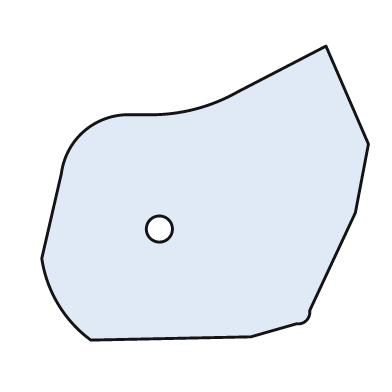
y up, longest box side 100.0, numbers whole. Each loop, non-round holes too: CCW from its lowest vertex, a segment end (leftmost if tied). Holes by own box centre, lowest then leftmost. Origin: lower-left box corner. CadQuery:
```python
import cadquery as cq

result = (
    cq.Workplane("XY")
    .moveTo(15.0, 0.0)
    .lineTo(64.0, 1.0)
    .lineTo(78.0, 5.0)
    .threePointArc((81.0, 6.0), (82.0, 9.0))
    .lineTo(96.0, 39.0)
    .lineTo(100.0, 60.0)
    .lineTo(87.0, 90.0)
    .lineTo(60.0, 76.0)
    .threePointArc((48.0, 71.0), (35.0, 69.0))
    .lineTo(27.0, 69.0)
    .threePointArc((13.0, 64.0), (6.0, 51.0))
    .lineTo(0.0, 25.0)
    .threePointArc((5.0, 11.0), (15.0, 0.0))
    .close()
    .moveTo(36.0, 34.0)
    .circle(4.0)
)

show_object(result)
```